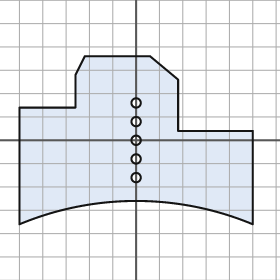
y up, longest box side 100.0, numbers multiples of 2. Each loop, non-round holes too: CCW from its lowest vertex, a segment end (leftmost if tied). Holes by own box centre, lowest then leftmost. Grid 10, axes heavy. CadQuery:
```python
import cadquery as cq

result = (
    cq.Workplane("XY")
    .moveTo(-50.0, -36.0)
    .threePointArc((0.0, -26.0), (50.0, -36.0))
    .lineTo(50.0, 4.0)
    .lineTo(18.0, 4.0)
    .lineTo(18.0, 26.0)
    .lineTo(6.0, 36.0)
    .lineTo(-22.0, 36.0)
    .lineTo(-26.0, 28.0)
    .lineTo(-26.0, 14.0)
    .lineTo(-50.0, 14.0)
    .close()
    .moveTo(0.0, -16.0)
    .circle(2.0)
    .moveTo(0.0, -8.0)
    .circle(2.0)
    .moveTo(0.0, 0.0)
    .circle(2.0)
    .moveTo(0.0, 8.0)
    .circle(2.0)
    .moveTo(0.0, 16.0)
    .circle(2.0)
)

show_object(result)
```